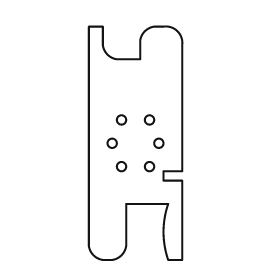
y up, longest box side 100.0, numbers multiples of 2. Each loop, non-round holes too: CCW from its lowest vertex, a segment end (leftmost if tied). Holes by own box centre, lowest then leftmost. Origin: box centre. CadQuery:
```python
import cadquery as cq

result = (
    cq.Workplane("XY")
    .moveTo(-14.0, -50.0)
    .lineTo(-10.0, -50.0)
    .threePointArc((-6.0, -48.0), (-4.0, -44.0))
    .lineTo(-4.0, -26.0)
    .lineTo(14.0, -26.0)
    .threePointArc((12.0, -38.0), (14.0, -50.0))
    .lineTo(20.0, -50.0)
    .lineTo(20.0, -16.0)
    .lineTo(12.0, -16.0)
    .lineTo(12.0, -12.0)
    .lineTo(20.0, -12.0)
    .lineTo(20.0, 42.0)
    .threePointArc((18.0, 48.0), (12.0, 50.0))
    .lineTo(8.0, 50.0)
    .threePointArc((4.0, 48.0), (2.0, 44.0))
    .lineTo(2.0, 36.0)
    .lineTo(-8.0, 36.0)
    .threePointArc((-12.0, 38.0), (-14.0, 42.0))
    .lineTo(-14.0, 50.0)
    .lineTo(-20.0, 50.0)
    .lineTo(-20.0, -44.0)
    .threePointArc((-18.0, -48.0), (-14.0, -50.0))
    .close()
    .moveTo(-6.0, -10.0)
    .circle(2.0)
    .moveTo(6.0, -10.0)
    .circle(2.0)
    .moveTo(-10.0, 0.0)
    .circle(2.0)
    .moveTo(10.0, 0.0)
    .circle(2.0)
    .moveTo(-6.0, 10.0)
    .circle(2.0)
    .moveTo(6.0, 10.0)
    .circle(2.0)
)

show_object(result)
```